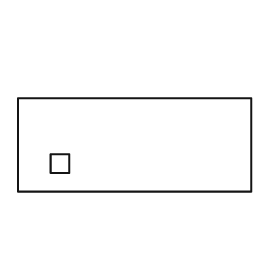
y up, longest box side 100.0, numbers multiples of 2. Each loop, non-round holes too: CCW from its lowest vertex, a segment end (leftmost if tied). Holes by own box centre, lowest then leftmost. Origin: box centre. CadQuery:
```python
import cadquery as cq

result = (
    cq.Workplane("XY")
    .moveTo(-50.0, -20.0)
    .lineTo(50.0, -20.0)
    .lineTo(50.0, 20.0)
    .lineTo(-50.0, 20.0)
    .close()
    .moveTo(-36.0, -12.0)
    .lineTo(-28.0, -12.0)
    .lineTo(-28.0, -4.0)
    .lineTo(-36.0, -4.0)
    .close()
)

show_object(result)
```